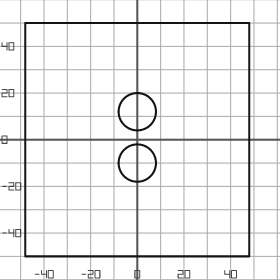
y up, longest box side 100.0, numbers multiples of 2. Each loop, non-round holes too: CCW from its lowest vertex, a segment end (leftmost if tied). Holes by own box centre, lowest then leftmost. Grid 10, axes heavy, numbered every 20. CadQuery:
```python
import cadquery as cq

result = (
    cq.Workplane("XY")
    .moveTo(-48.0, -50.0)
    .lineTo(48.0, -50.0)
    .lineTo(48.0, 50.0)
    .lineTo(-48.0, 50.0)
    .close()
    .moveTo(0.0, -10.0)
    .circle(8.0)
    .moveTo(0.0, 12.0)
    .circle(8.0)
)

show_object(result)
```